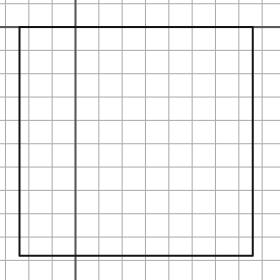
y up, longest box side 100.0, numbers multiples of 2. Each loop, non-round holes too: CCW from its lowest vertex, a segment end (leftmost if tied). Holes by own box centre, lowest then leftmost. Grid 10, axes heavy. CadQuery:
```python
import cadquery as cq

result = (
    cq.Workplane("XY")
    .moveTo(-24.0, -98.0)
    .lineTo(76.0, -98.0)
    .lineTo(76.0, 0.0)
    .lineTo(-24.0, 0.0)
    .close()
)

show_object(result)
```